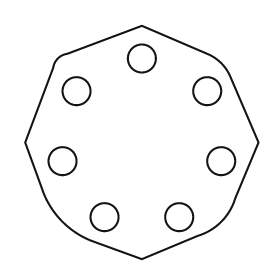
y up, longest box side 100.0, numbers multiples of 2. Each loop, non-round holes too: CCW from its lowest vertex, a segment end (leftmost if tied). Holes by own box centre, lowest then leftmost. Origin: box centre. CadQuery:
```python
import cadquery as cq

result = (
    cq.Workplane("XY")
    .moveTo(0.0, -50.0)
    .lineTo(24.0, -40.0)
    .threePointArc((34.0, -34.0), (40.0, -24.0))
    .lineTo(50.0, 0.0)
    .lineTo(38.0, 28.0)
    .threePointArc((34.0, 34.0), (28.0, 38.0))
    .lineTo(0.0, 50.0)
    .lineTo(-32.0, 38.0)
    .threePointArc((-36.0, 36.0), (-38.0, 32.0))
    .lineTo(-50.0, 0.0)
    .lineTo(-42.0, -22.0)
    .threePointArc((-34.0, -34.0), (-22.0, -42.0))
    .close()
    .moveTo(-16.0, -32.0)
    .circle(6.0)
    .moveTo(16.0, -32.0)
    .circle(6.0)
    .moveTo(-34.0, -8.0)
    .circle(6.0)
    .moveTo(34.0, -8.0)
    .circle(6.0)
    .moveTo(-28.0, 22.0)
    .circle(6.0)
    .moveTo(28.0, 22.0)
    .circle(6.0)
    .moveTo(0.0, 36.0)
    .circle(6.0)
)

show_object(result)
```